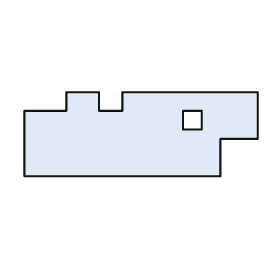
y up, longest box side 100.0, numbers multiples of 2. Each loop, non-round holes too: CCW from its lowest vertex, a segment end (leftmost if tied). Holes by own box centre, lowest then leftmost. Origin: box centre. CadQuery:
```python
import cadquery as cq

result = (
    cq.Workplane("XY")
    .moveTo(-50.0, -18.0)
    .lineTo(34.0, -18.0)
    .lineTo(34.0, -2.0)
    .lineTo(50.0, -2.0)
    .lineTo(50.0, 18.0)
    .lineTo(-8.0, 18.0)
    .lineTo(-8.0, 10.0)
    .lineTo(-18.0, 10.0)
    .lineTo(-18.0, 18.0)
    .lineTo(-32.0, 18.0)
    .lineTo(-32.0, 10.0)
    .lineTo(-50.0, 10.0)
    .close()
    .moveTo(18.0, 2.0)
    .lineTo(26.0, 2.0)
    .lineTo(26.0, 10.0)
    .lineTo(18.0, 10.0)
    .close()
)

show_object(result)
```